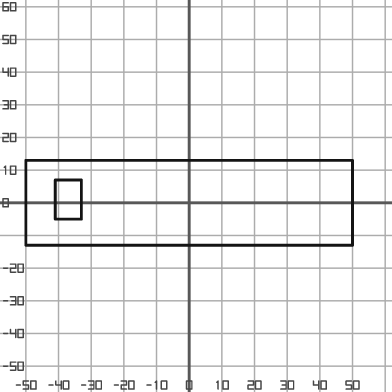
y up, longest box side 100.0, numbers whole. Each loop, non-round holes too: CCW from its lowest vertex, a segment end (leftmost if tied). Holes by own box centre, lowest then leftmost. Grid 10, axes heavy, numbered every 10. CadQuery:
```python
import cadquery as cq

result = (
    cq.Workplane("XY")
    .moveTo(-50.0, -13.0)
    .lineTo(50.0, -13.0)
    .lineTo(50.0, 13.0)
    .lineTo(-50.0, 13.0)
    .close()
    .moveTo(-41.0, -5.0)
    .lineTo(-33.0, -5.0)
    .lineTo(-33.0, 7.0)
    .lineTo(-41.0, 7.0)
    .close()
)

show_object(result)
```